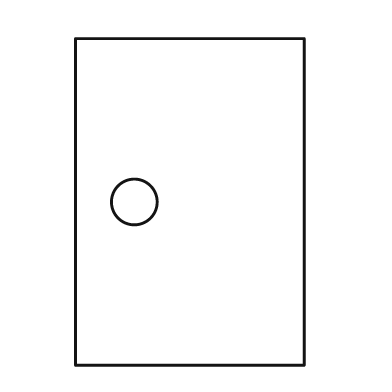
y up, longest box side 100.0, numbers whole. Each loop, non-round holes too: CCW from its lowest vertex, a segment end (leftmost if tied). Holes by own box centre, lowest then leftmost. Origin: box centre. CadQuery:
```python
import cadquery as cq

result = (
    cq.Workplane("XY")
    .moveTo(-35.0, -50.0)
    .lineTo(35.0, -50.0)
    .lineTo(35.0, 50.0)
    .lineTo(-35.0, 50.0)
    .close()
    .moveTo(-17.0, 0.0)
    .circle(7.0)
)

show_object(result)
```